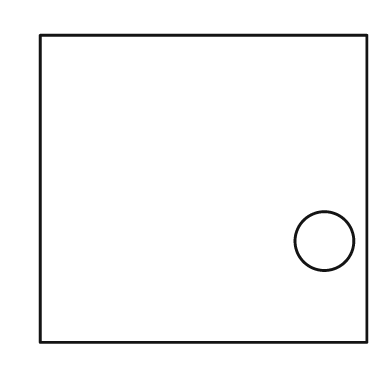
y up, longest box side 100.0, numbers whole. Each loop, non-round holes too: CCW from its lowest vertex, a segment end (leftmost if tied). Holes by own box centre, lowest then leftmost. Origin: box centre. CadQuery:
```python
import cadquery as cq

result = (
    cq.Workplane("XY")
    .moveTo(-50.0, -47.0)
    .lineTo(50.0, -47.0)
    .lineTo(50.0, 47.0)
    .lineTo(-50.0, 47.0)
    .close()
    .moveTo(37.0, -16.0)
    .circle(9.0)
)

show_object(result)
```